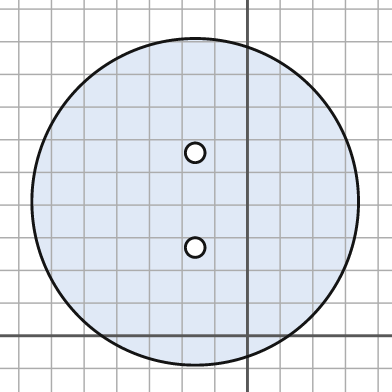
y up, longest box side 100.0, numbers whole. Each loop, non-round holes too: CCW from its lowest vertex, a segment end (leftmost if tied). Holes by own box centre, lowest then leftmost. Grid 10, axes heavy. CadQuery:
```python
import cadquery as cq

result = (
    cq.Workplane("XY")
    .moveTo(-16.0, 41.0)
    .circle(50.0)
    .moveTo(-16.0, 27.0)
    .circle(3.0)
    .moveTo(-16.0, 56.0)
    .circle(3.0)
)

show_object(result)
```